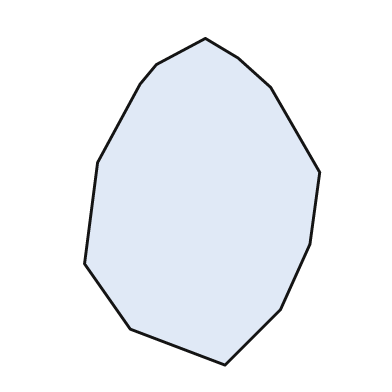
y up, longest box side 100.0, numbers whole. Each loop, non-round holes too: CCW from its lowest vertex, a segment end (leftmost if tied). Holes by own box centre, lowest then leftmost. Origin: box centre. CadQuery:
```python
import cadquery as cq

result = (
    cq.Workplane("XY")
    .moveTo(7.0, -50.0)
    .lineTo(24.0, -33.0)
    .lineTo(33.0, -13.0)
    .lineTo(36.0, 9.0)
    .lineTo(21.0, 35.0)
    .lineTo(11.0, 44.0)
    .lineTo(1.0, 50.0)
    .lineTo(-14.0, 42.0)
    .lineTo(-19.0, 36.0)
    .lineTo(-32.0, 12.0)
    .lineTo(-36.0, -19.0)
    .lineTo(-22.0, -39.0)
    .close()
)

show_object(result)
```